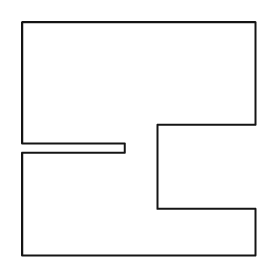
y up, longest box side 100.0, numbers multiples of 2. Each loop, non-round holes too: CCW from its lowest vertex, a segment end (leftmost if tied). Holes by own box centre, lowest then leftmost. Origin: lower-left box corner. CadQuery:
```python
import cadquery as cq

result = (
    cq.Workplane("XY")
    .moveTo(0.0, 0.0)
    .lineTo(100.0, 0.0)
    .lineTo(100.0, 20.0)
    .lineTo(58.0, 20.0)
    .lineTo(58.0, 56.0)
    .lineTo(100.0, 56.0)
    .lineTo(100.0, 100.0)
    .lineTo(0.0, 100.0)
    .lineTo(0.0, 48.0)
    .lineTo(44.0, 48.0)
    .lineTo(44.0, 44.0)
    .lineTo(0.0, 44.0)
    .close()
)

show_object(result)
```